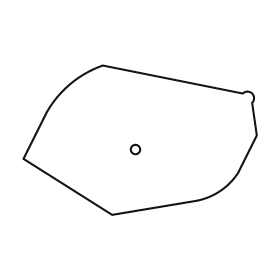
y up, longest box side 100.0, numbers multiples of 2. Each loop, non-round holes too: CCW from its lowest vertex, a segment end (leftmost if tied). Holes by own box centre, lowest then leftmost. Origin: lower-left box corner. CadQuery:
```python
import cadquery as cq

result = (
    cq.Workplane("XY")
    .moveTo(38.0, 0.0)
    .lineTo(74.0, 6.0)
    .threePointArc((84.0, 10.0), (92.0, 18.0))
    .lineTo(100.0, 34.0)
    .lineTo(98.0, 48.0)
    .threePointArc((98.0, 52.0), (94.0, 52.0))
    .lineTo(34.0, 64.0)
    .threePointArc((20.0, 56.0), (10.0, 44.0))
    .lineTo(0.0, 24.0)
    .close()
    .moveTo(48.0, 28.0)
    .circle(2.0)
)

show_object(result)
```